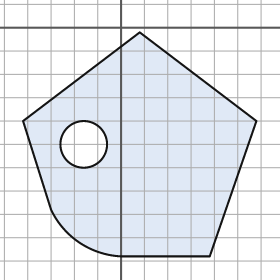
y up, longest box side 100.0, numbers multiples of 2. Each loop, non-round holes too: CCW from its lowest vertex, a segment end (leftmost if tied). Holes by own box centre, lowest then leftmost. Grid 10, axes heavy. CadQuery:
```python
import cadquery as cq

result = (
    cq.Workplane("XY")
    .moveTo(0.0, -98.0)
    .lineTo(38.0, -98.0)
    .lineTo(58.0, -40.0)
    .lineTo(8.0, -2.0)
    .lineTo(-42.0, -40.0)
    .lineTo(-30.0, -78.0)
    .threePointArc((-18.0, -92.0), (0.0, -98.0))
    .close()
    .moveTo(-16.0, -50.0)
    .circle(10.0)
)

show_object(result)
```